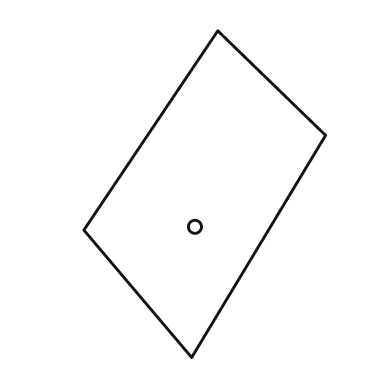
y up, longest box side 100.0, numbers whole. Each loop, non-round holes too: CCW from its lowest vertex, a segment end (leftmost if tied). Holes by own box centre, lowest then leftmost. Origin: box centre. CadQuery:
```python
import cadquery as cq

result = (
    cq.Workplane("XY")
    .moveTo(-4.0, -50.0)
    .lineTo(37.0, 18.0)
    .lineTo(4.0, 50.0)
    .lineTo(-37.0, -11.0)
    .close()
    .moveTo(-3.0, -10.0)
    .circle(2.0)
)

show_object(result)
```